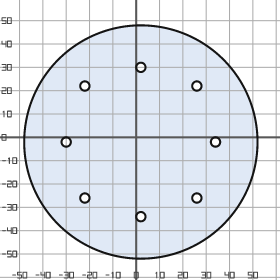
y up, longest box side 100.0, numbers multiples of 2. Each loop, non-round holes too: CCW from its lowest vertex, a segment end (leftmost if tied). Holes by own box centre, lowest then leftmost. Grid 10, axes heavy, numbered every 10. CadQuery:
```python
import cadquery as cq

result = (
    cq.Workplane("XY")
    .moveTo(2.0, -2.0)
    .circle(50.0)
    .moveTo(2.0, -34.0)
    .circle(2.0)
    .moveTo(-22.0, -26.0)
    .circle(2.0)
    .moveTo(26.0, -26.0)
    .circle(2.0)
    .moveTo(-30.0, -2.0)
    .circle(2.0)
    .moveTo(34.0, -2.0)
    .circle(2.0)
    .moveTo(-22.0, 22.0)
    .circle(2.0)
    .moveTo(26.0, 22.0)
    .circle(2.0)
    .moveTo(2.0, 30.0)
    .circle(2.0)
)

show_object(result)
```